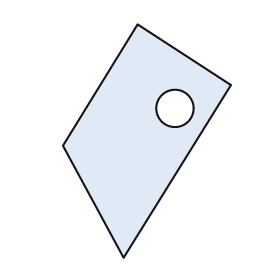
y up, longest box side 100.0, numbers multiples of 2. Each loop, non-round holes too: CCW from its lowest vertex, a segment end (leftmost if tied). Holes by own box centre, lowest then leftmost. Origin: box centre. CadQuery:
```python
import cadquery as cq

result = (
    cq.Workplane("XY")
    .moveTo(-10.0, -50.0)
    .lineTo(36.0, 24.0)
    .lineTo(-4.0, 50.0)
    .lineTo(-36.0, -2.0)
    .close()
    .moveTo(12.0, 14.0)
    .circle(8.0)
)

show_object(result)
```